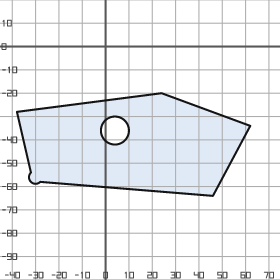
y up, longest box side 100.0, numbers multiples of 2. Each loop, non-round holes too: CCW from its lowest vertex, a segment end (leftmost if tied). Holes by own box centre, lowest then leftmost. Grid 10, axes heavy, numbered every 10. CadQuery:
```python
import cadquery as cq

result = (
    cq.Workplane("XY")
    .moveTo(46.0, -64.0)
    .lineTo(62.0, -34.0)
    .lineTo(24.0, -20.0)
    .lineTo(-38.0, -28.0)
    .lineTo(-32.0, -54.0)
    .threePointArc((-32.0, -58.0), (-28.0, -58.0))
    .close()
    .moveTo(4.0, -36.0)
    .circle(6.0)
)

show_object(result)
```